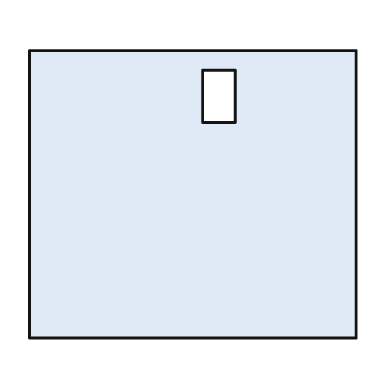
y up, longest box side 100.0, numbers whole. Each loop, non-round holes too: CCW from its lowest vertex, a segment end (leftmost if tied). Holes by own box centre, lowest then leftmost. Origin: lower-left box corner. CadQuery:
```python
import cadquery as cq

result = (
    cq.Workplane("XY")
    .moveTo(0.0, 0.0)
    .lineTo(100.0, 0.0)
    .lineTo(100.0, 88.0)
    .lineTo(0.0, 88.0)
    .close()
    .moveTo(53.0, 66.0)
    .lineTo(63.0, 66.0)
    .lineTo(63.0, 82.0)
    .lineTo(53.0, 82.0)
    .close()
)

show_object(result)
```